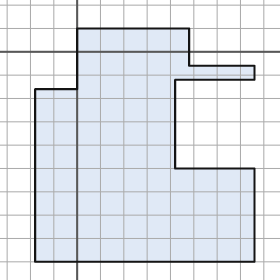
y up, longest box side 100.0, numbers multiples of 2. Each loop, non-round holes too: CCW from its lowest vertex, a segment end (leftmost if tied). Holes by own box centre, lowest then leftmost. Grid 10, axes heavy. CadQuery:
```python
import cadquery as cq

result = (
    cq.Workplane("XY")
    .moveTo(-18.0, -90.0)
    .lineTo(76.0, -90.0)
    .lineTo(76.0, -50.0)
    .lineTo(42.0, -50.0)
    .lineTo(42.0, -12.0)
    .lineTo(76.0, -12.0)
    .lineTo(76.0, -6.0)
    .lineTo(48.0, -6.0)
    .lineTo(48.0, 10.0)
    .lineTo(0.0, 10.0)
    .lineTo(0.0, -16.0)
    .lineTo(-18.0, -16.0)
    .close()
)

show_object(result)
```